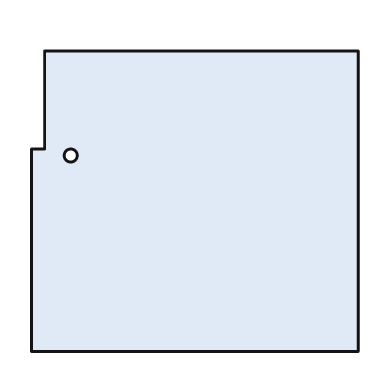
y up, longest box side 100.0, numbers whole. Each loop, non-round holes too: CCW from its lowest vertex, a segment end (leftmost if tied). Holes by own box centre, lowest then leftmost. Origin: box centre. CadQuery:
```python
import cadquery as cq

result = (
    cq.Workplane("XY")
    .moveTo(-50.0, -46.0)
    .lineTo(50.0, -46.0)
    .lineTo(50.0, 46.0)
    .lineTo(-46.0, 46.0)
    .lineTo(-46.0, 16.0)
    .lineTo(-50.0, 16.0)
    .close()
    .moveTo(-38.0, 14.0)
    .circle(2.0)
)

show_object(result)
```